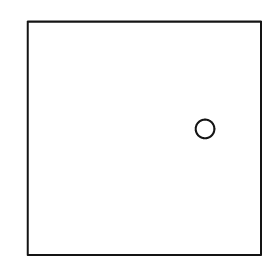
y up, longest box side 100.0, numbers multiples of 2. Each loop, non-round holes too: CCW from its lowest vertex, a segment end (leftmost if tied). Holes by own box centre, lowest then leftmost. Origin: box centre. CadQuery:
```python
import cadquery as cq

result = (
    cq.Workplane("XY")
    .moveTo(-50.0, -50.0)
    .lineTo(50.0, -50.0)
    .lineTo(50.0, 50.0)
    .lineTo(-50.0, 50.0)
    .close()
    .moveTo(26.0, 4.0)
    .circle(4.0)
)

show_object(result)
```